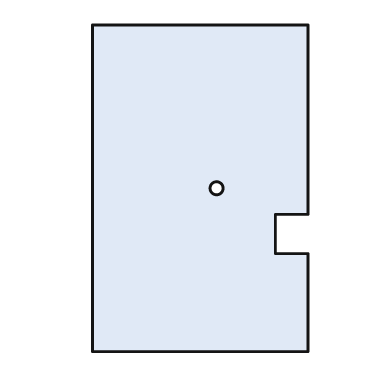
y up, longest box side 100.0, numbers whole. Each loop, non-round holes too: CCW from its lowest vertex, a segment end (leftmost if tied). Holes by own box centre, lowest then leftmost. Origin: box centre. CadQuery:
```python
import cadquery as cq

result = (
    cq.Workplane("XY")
    .moveTo(-33.0, -50.0)
    .lineTo(33.0, -50.0)
    .lineTo(33.0, -20.0)
    .lineTo(23.0, -20.0)
    .lineTo(23.0, -8.0)
    .lineTo(33.0, -8.0)
    .lineTo(33.0, 50.0)
    .lineTo(-33.0, 50.0)
    .close()
    .moveTo(5.0, 0.0)
    .circle(2.0)
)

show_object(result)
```